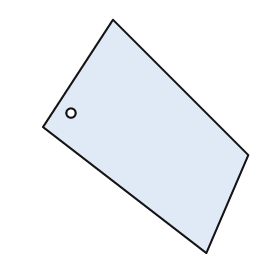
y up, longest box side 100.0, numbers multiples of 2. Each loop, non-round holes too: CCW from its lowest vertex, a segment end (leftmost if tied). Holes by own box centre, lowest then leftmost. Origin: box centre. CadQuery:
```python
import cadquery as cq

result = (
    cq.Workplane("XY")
    .moveTo(26.0, -50.0)
    .lineTo(44.0, -8.0)
    .lineTo(-14.0, 50.0)
    .lineTo(-44.0, 4.0)
    .close()
    .moveTo(-32.0, 10.0)
    .circle(2.0)
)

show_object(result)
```